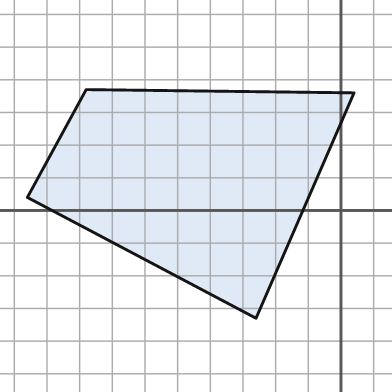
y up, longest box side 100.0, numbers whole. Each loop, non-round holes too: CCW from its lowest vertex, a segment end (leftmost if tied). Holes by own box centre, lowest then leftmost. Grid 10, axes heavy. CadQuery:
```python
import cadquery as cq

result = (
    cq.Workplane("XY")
    .moveTo(-26.0, -33.0)
    .lineTo(4.0, 36.0)
    .lineTo(-78.0, 37.0)
    .lineTo(-96.0, 4.0)
    .close()
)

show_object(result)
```